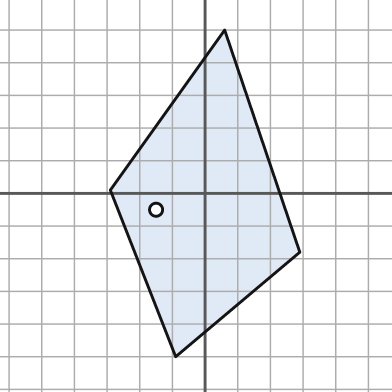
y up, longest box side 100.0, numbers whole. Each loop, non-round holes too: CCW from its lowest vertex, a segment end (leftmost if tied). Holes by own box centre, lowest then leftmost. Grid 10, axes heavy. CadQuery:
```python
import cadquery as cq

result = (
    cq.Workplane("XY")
    .moveTo(-9.0, -50.0)
    .lineTo(29.0, -18.0)
    .lineTo(6.0, 50.0)
    .lineTo(-29.0, 1.0)
    .close()
    .moveTo(-15.0, -5.0)
    .circle(2.0)
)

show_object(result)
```